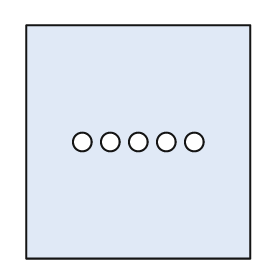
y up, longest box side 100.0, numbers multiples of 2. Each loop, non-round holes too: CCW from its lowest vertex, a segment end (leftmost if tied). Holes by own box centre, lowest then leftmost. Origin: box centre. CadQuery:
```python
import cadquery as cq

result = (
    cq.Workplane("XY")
    .moveTo(-48.0, -50.0)
    .lineTo(48.0, -50.0)
    .lineTo(48.0, 50.0)
    .lineTo(-48.0, 50.0)
    .close()
    .moveTo(-24.0, 0.0)
    .circle(4.0)
    .moveTo(-12.0, 0.0)
    .circle(4.0)
    .moveTo(0.0, 0.0)
    .circle(4.0)
    .moveTo(12.0, 0.0)
    .circle(4.0)
    .moveTo(24.0, 0.0)
    .circle(4.0)
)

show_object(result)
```